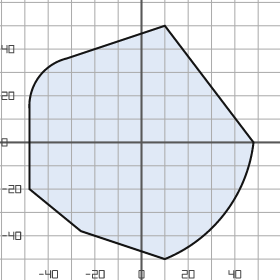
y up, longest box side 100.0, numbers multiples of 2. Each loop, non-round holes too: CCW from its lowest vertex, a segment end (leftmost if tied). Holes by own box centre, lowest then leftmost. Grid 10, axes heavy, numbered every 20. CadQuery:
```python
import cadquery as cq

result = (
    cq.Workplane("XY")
    .moveTo(10.0, -50.0)
    .threePointArc((36.0, -30.0), (48.0, 0.0))
    .lineTo(10.0, 50.0)
    .lineTo(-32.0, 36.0)
    .threePointArc((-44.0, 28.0), (-48.0, 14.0))
    .lineTo(-48.0, -20.0)
    .lineTo(-26.0, -38.0)
    .close()
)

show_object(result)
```